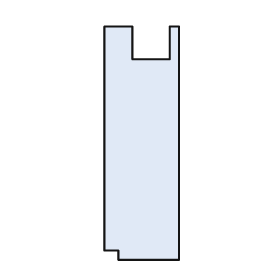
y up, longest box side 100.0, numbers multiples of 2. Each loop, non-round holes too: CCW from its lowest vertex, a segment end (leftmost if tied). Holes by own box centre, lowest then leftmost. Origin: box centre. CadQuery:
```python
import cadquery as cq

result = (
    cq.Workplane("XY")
    .moveTo(-10.0, -50.0)
    .lineTo(16.0, -50.0)
    .lineTo(16.0, 50.0)
    .lineTo(12.0, 50.0)
    .lineTo(12.0, 36.0)
    .lineTo(-4.0, 36.0)
    .lineTo(-4.0, 50.0)
    .lineTo(-16.0, 50.0)
    .lineTo(-16.0, -46.0)
    .lineTo(-10.0, -46.0)
    .close()
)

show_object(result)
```